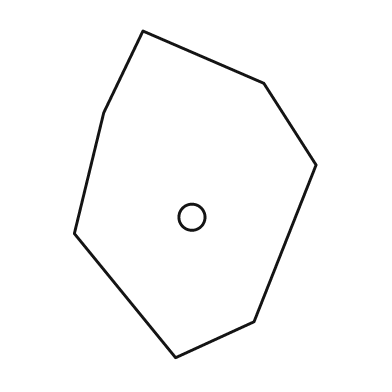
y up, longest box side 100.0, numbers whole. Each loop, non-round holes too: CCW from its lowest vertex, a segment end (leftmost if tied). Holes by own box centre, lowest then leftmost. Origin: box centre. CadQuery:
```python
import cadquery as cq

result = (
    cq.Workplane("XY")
    .moveTo(-6.0, -50.0)
    .lineTo(18.0, -39.0)
    .lineTo(37.0, 9.0)
    .lineTo(21.0, 34.0)
    .lineTo(-16.0, 50.0)
    .lineTo(-28.0, 25.0)
    .lineTo(-37.0, -12.0)
    .close()
    .moveTo(-1.0, -7.0)
    .circle(4.0)
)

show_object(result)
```